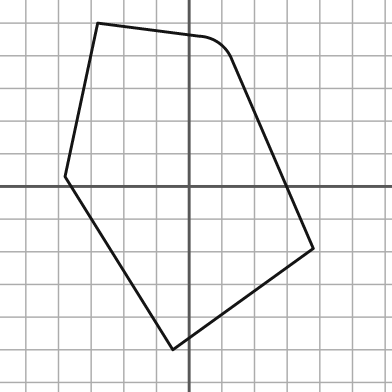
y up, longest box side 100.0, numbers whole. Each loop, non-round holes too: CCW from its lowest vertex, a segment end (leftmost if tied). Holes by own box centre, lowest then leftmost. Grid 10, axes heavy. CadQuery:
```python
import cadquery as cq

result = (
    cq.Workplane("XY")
    .moveTo(-5.0, -50.0)
    .lineTo(38.0, -19.0)
    .lineTo(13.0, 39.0)
    .threePointArc((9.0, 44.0), (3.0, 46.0))
    .lineTo(-28.0, 50.0)
    .lineTo(-38.0, 3.0)
    .close()
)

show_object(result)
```